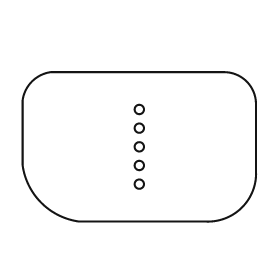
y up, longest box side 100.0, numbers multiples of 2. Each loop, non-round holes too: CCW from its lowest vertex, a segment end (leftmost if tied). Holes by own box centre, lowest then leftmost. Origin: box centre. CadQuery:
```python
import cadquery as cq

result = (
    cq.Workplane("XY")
    .moveTo(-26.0, -32.0)
    .lineTo(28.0, -32.0)
    .threePointArc((44.0, -26.0), (50.0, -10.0))
    .lineTo(50.0, 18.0)
    .threePointArc((46.0, 28.0), (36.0, 32.0))
    .lineTo(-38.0, 32.0)
    .threePointArc((-46.0, 28.0), (-50.0, 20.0))
    .lineTo(-50.0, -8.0)
    .threePointArc((-42.0, -24.0), (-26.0, -32.0))
    .close()
    .moveTo(0.0, -16.0)
    .circle(2.0)
    .moveTo(0.0, -8.0)
    .circle(2.0)
    .moveTo(0.0, 0.0)
    .circle(2.0)
    .moveTo(0.0, 8.0)
    .circle(2.0)
    .moveTo(0.0, 16.0)
    .circle(2.0)
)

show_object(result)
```